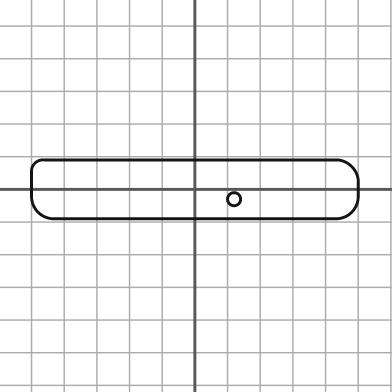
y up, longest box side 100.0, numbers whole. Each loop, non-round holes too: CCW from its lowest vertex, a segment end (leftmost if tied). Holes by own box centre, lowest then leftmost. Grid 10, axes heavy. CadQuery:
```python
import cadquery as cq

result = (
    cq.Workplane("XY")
    .moveTo(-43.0, -9.0)
    .lineTo(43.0, -9.0)
    .threePointArc((48.0, -7.0), (50.0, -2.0))
    .lineTo(50.0, 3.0)
    .threePointArc((48.0, 7.0), (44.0, 9.0))
    .lineTo(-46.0, 9.0)
    .threePointArc((-49.0, 8.0), (-50.0, 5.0))
    .lineTo(-50.0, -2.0)
    .threePointArc((-48.0, -7.0), (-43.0, -9.0))
    .close()
    .moveTo(12.0, -3.0)
    .circle(2.0)
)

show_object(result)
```